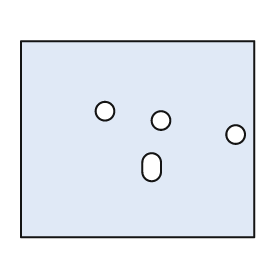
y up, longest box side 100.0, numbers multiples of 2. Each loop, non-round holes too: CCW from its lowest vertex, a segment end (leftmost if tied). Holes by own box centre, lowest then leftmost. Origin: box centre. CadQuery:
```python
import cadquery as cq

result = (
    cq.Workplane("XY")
    .moveTo(-50.0, -42.0)
    .lineTo(50.0, -42.0)
    .lineTo(50.0, 42.0)
    .lineTo(-50.0, 42.0)
    .close()
    .moveTo(2.0, -14.0)
    .threePointArc((6.0, -18.0), (10.0, -14.0))
    .lineTo(10.0, -10.0)
    .threePointArc((6.0, -6.0), (2.0, -10.0))
    .close()
    .moveTo(42.0, 2.0)
    .circle(4.0)
    .moveTo(10.0, 8.0)
    .circle(4.0)
    .moveTo(-14.0, 12.0)
    .circle(4.0)
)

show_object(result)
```